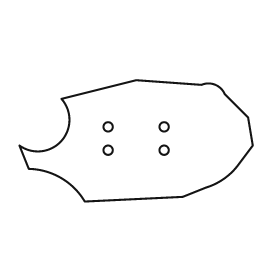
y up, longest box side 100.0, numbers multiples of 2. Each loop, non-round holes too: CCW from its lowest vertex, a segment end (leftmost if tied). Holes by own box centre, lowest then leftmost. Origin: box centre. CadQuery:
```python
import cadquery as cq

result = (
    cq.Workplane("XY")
    .moveTo(-22.0, -26.0)
    .lineTo(20.0, -24.0)
    .lineTo(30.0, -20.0)
    .threePointArc((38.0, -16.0), (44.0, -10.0))
    .lineTo(50.0, -2.0)
    .lineTo(48.0, 10.0)
    .lineTo(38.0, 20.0)
    .threePointArc((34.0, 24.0), (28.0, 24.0))
    .lineTo(0.0, 26.0)
    .lineTo(-32.0, 18.0)
    .threePointArc((-32.0, 0.0), (-50.0, -2.0))
    .lineTo(-46.0, -12.0)
    .threePointArc((-32.0, -16.0), (-22.0, -26.0))
    .close()
    .moveTo(-12.0, -4.0)
    .circle(2.0)
    .moveTo(12.0, -4.0)
    .circle(2.0)
    .moveTo(-12.0, 6.0)
    .circle(2.0)
    .moveTo(12.0, 6.0)
    .circle(2.0)
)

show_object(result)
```